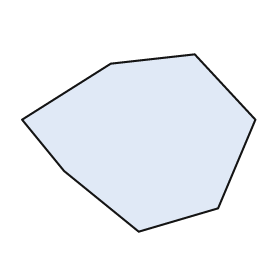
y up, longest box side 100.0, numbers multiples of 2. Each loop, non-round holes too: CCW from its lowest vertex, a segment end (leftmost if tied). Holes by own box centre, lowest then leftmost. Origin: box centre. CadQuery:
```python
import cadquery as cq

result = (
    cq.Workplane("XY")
    .moveTo(0.0, -38.0)
    .lineTo(34.0, -28.0)
    .lineTo(50.0, 10.0)
    .lineTo(24.0, 38.0)
    .lineTo(-12.0, 34.0)
    .lineTo(-50.0, 10.0)
    .lineTo(-32.0, -12.0)
    .close()
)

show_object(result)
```